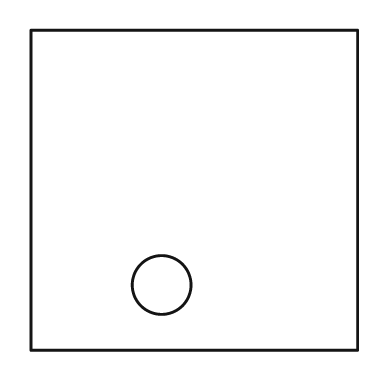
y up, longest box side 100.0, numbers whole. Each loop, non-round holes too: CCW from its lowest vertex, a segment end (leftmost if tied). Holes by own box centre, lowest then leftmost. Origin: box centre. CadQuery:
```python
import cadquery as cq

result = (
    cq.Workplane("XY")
    .moveTo(-50.0, -49.0)
    .lineTo(50.0, -49.0)
    .lineTo(50.0, 49.0)
    .lineTo(-50.0, 49.0)
    .close()
    .moveTo(-10.0, -29.0)
    .circle(9.0)
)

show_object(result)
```